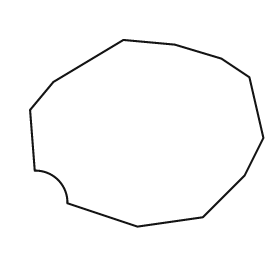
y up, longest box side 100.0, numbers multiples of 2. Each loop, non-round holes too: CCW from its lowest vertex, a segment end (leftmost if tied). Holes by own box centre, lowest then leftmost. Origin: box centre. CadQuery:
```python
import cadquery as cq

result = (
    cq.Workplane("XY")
    .moveTo(-4.0, -40.0)
    .lineTo(24.0, -36.0)
    .lineTo(42.0, -18.0)
    .lineTo(50.0, -2.0)
    .lineTo(44.0, 24.0)
    .lineTo(32.0, 32.0)
    .lineTo(12.0, 38.0)
    .lineTo(-10.0, 40.0)
    .lineTo(-40.0, 22.0)
    .lineTo(-50.0, 10.0)
    .lineTo(-48.0, -16.0)
    .threePointArc((-38.0, -20.0), (-34.0, -30.0))
    .close()
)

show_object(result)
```